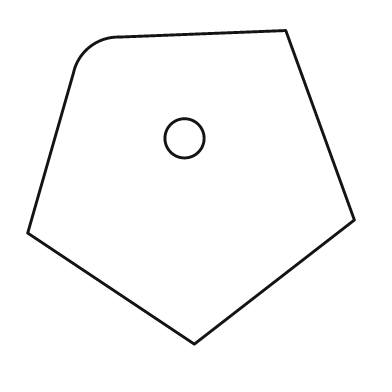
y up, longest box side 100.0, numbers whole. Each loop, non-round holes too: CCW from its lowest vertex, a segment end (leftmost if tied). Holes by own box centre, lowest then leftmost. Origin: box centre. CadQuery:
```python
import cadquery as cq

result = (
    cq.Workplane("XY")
    .moveTo(1.0, -48.0)
    .lineTo(50.0, -10.0)
    .lineTo(29.0, 48.0)
    .lineTo(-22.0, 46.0)
    .threePointArc((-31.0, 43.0), (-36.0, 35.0))
    .lineTo(-50.0, -14.0)
    .close()
    .moveTo(-2.0, 15.0)
    .circle(6.0)
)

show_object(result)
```